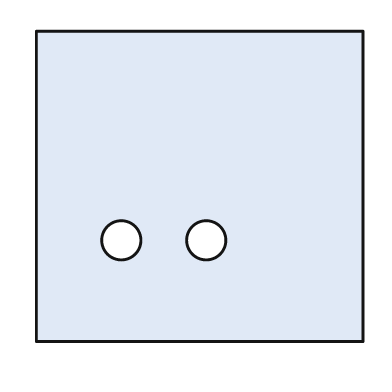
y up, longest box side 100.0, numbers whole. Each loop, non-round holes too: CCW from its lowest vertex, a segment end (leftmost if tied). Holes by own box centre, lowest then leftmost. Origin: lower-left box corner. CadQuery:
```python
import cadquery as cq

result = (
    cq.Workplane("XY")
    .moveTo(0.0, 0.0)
    .lineTo(100.0, 0.0)
    .lineTo(100.0, 95.0)
    .lineTo(0.0, 95.0)
    .close()
    .moveTo(26.0, 31.0)
    .circle(6.0)
    .moveTo(52.0, 31.0)
    .circle(6.0)
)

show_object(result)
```